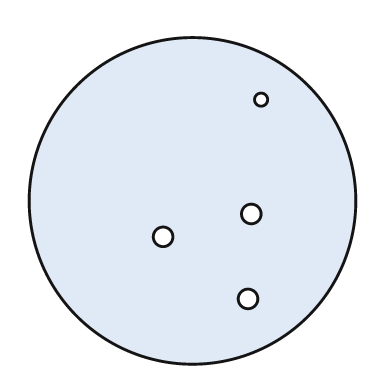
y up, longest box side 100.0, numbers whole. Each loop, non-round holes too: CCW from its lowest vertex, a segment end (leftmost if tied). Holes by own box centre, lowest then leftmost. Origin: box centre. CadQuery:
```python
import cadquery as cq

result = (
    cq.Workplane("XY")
    .moveTo(0.0, 0.0)
    .circle(50.0)
    .moveTo(17.0, -30.0)
    .circle(3.0)
    .moveTo(-9.0, -11.0)
    .circle(3.0)
    .moveTo(18.0, -4.0)
    .circle(3.0)
    .moveTo(21.0, 31.0)
    .circle(2.0)
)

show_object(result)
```